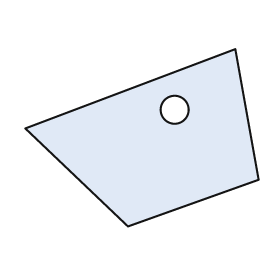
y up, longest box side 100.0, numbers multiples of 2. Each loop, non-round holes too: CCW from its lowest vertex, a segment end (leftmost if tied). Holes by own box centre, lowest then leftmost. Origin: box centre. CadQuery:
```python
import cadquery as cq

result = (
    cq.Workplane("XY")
    .moveTo(-6.0, -38.0)
    .lineTo(50.0, -18.0)
    .lineTo(40.0, 38.0)
    .lineTo(-50.0, 4.0)
    .close()
    .moveTo(14.0, 12.0)
    .circle(6.0)
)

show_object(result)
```